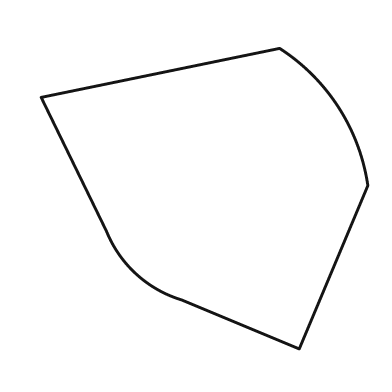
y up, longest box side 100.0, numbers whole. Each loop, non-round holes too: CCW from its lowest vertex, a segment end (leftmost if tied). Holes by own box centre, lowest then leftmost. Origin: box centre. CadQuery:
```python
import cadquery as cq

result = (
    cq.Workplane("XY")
    .moveTo(29.0, -46.0)
    .lineTo(50.0, 4.0)
    .threePointArc((41.0, 28.0), (23.0, 46.0))
    .lineTo(-50.0, 31.0)
    .lineTo(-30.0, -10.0)
    .threePointArc((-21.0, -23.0), (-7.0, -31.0))
    .close()
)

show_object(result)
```